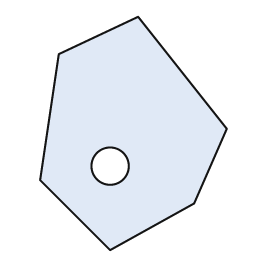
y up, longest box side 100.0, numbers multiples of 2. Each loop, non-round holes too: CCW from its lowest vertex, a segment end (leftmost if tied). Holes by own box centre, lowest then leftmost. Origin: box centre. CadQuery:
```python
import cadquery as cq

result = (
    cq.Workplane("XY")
    .moveTo(-10.0, -50.0)
    .lineTo(26.0, -30.0)
    .lineTo(40.0, 2.0)
    .lineTo(2.0, 50.0)
    .lineTo(-32.0, 34.0)
    .lineTo(-40.0, -20.0)
    .close()
    .moveTo(-10.0, -14.0)
    .circle(8.0)
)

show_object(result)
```